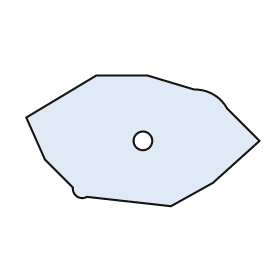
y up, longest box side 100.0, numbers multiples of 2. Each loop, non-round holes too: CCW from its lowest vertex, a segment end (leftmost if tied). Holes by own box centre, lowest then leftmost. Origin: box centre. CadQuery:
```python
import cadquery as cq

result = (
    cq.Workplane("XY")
    .moveTo(12.0, -28.0)
    .lineTo(30.0, -18.0)
    .lineTo(50.0, 0.0)
    .lineTo(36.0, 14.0)
    .threePointArc((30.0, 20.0), (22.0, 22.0))
    .lineTo(2.0, 28.0)
    .lineTo(-20.0, 28.0)
    .lineTo(-50.0, 10.0)
    .lineTo(-42.0, -8.0)
    .lineTo(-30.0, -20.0)
    .threePointArc((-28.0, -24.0), (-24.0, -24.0))
    .close()
    .moveTo(0.0, 0.0)
    .circle(4.0)
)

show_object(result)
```